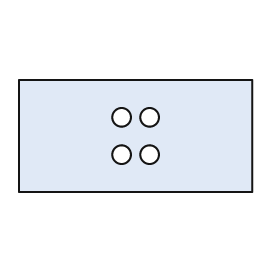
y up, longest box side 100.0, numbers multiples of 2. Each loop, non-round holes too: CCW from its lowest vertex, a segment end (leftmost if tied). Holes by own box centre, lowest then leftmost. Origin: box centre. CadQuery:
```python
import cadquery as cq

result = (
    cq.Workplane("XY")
    .moveTo(-50.0, -24.0)
    .lineTo(50.0, -24.0)
    .lineTo(50.0, 24.0)
    .lineTo(-50.0, 24.0)
    .close()
    .moveTo(-6.0, -8.0)
    .circle(4.0)
    .moveTo(6.0, -8.0)
    .circle(4.0)
    .moveTo(-6.0, 8.0)
    .circle(4.0)
    .moveTo(6.0, 8.0)
    .circle(4.0)
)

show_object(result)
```